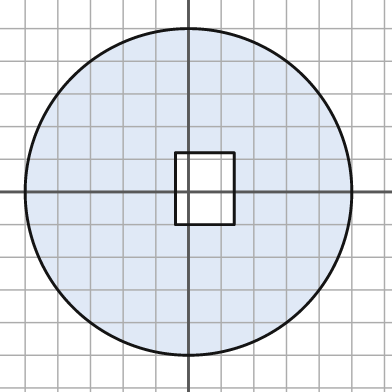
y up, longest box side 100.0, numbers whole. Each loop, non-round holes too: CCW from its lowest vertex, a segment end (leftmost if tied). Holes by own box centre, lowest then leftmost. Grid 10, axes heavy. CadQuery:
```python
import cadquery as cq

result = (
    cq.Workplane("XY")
    .moveTo(0.0, 0.0)
    .circle(50.0)
    .moveTo(-4.0, -10.0)
    .lineTo(14.0, -10.0)
    .lineTo(14.0, 12.0)
    .lineTo(-4.0, 12.0)
    .close()
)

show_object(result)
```